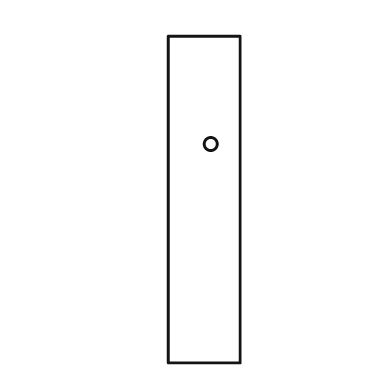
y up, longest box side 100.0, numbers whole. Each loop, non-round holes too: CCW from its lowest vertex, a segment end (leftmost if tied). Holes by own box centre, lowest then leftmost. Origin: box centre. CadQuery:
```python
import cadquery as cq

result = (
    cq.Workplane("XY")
    .moveTo(-11.0, -50.0)
    .lineTo(11.0, -50.0)
    .lineTo(11.0, 50.0)
    .lineTo(-11.0, 50.0)
    .close()
    .moveTo(2.0, 17.0)
    .circle(2.0)
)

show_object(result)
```